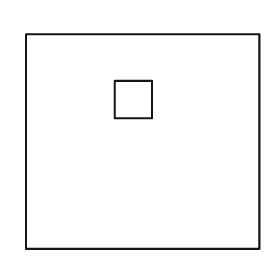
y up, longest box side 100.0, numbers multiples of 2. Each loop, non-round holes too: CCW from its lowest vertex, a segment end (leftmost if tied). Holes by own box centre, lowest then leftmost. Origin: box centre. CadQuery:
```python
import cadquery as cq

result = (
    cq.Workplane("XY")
    .moveTo(-50.0, -46.0)
    .lineTo(50.0, -46.0)
    .lineTo(50.0, 46.0)
    .lineTo(-50.0, 46.0)
    .close()
    .moveTo(-12.0, 10.0)
    .lineTo(4.0, 10.0)
    .lineTo(4.0, 26.0)
    .lineTo(-12.0, 26.0)
    .close()
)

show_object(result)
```